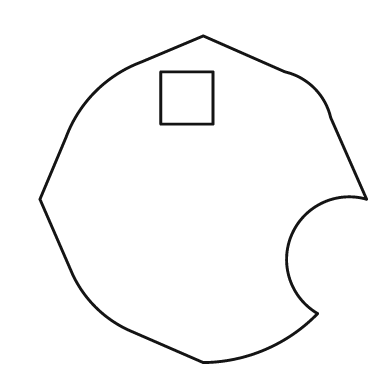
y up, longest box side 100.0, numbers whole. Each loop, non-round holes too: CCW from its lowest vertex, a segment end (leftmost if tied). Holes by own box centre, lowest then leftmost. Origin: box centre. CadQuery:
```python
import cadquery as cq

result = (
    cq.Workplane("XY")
    .moveTo(0.0, -50.0)
    .threePointArc((19.0, -46.0), (35.0, -35.0))
    .threePointArc((27.0, -11.0), (50.0, 0.0))
    .lineTo(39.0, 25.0)
    .threePointArc((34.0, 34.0), (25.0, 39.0))
    .lineTo(0.0, 50.0)
    .lineTo(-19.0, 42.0)
    .threePointArc((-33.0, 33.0), (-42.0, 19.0))
    .lineTo(-50.0, 0.0)
    .lineTo(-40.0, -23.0)
    .threePointArc((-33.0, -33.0), (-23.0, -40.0))
    .close()
    .moveTo(-13.0, 23.0)
    .lineTo(3.0, 23.0)
    .lineTo(3.0, 39.0)
    .lineTo(-13.0, 39.0)
    .close()
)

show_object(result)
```